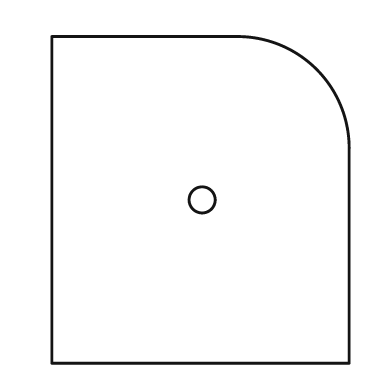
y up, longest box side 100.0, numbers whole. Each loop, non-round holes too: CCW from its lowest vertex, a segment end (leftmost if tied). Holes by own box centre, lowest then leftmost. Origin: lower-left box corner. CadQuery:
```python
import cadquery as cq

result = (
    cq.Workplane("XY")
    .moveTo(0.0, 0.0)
    .lineTo(91.0, 0.0)
    .lineTo(91.0, 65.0)
    .threePointArc((81.0, 90.0), (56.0, 100.0))
    .lineTo(0.0, 100.0)
    .close()
    .moveTo(46.0, 50.0)
    .circle(4.0)
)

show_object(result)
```